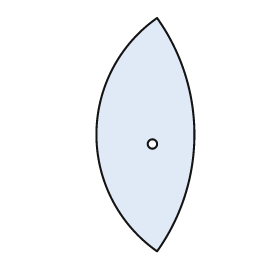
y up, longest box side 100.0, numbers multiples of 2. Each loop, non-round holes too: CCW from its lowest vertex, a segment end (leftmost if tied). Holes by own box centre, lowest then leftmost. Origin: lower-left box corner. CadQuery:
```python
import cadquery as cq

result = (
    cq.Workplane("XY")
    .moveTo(26.0, 0.0)
    .threePointArc((42.0, 50.0), (26.0, 100.0))
    .threePointArc((0.0, 50.0), (26.0, 0.0))
    .close()
    .moveTo(24.0, 46.0)
    .circle(2.0)
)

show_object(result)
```